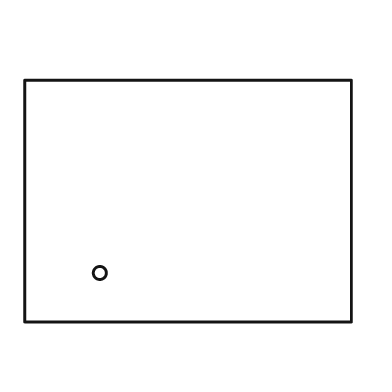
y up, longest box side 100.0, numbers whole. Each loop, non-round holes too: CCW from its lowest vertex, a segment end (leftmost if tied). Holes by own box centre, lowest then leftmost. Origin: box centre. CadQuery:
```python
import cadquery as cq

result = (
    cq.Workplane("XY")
    .moveTo(-50.0, -37.0)
    .lineTo(50.0, -37.0)
    .lineTo(50.0, 37.0)
    .lineTo(-50.0, 37.0)
    .close()
    .moveTo(-27.0, -22.0)
    .circle(2.0)
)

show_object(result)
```